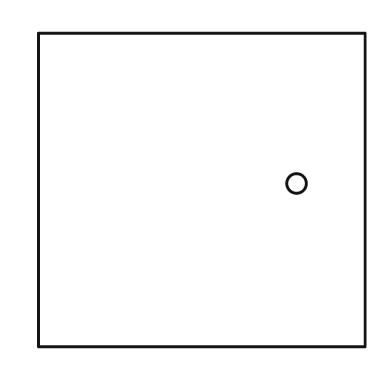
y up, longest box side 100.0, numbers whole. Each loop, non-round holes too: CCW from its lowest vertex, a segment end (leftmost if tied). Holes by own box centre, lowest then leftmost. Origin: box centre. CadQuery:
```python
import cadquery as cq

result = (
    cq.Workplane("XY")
    .moveTo(-50.0, -48.0)
    .lineTo(50.0, -48.0)
    .lineTo(50.0, 48.0)
    .lineTo(-50.0, 48.0)
    .close()
    .moveTo(29.0, 2.0)
    .circle(3.0)
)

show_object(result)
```